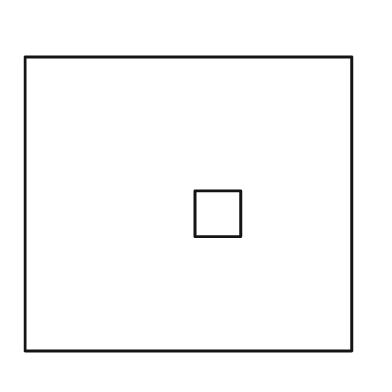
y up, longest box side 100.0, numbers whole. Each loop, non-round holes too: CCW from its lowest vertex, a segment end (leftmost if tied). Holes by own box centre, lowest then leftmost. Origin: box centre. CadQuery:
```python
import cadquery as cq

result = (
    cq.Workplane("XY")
    .moveTo(-50.0, -45.0)
    .lineTo(50.0, -45.0)
    .lineTo(50.0, 45.0)
    .lineTo(-50.0, 45.0)
    .close()
    .moveTo(2.0, -10.0)
    .lineTo(16.0, -10.0)
    .lineTo(16.0, 4.0)
    .lineTo(2.0, 4.0)
    .close()
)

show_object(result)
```